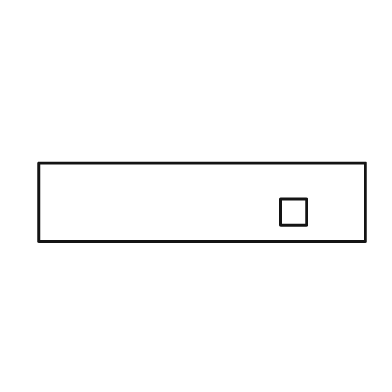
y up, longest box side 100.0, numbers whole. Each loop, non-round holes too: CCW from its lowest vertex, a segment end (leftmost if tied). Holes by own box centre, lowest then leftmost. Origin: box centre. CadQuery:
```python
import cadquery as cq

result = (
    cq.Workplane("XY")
    .moveTo(-50.0, -12.0)
    .lineTo(50.0, -12.0)
    .lineTo(50.0, 12.0)
    .lineTo(-50.0, 12.0)
    .close()
    .moveTo(24.0, -7.0)
    .lineTo(32.0, -7.0)
    .lineTo(32.0, 1.0)
    .lineTo(24.0, 1.0)
    .close()
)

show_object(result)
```